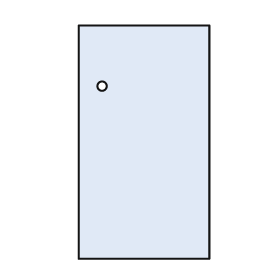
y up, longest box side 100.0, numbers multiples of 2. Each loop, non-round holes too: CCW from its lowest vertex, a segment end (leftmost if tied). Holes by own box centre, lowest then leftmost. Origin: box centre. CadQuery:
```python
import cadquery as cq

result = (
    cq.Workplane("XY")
    .moveTo(-28.0, -50.0)
    .lineTo(28.0, -50.0)
    .lineTo(28.0, 50.0)
    .lineTo(-28.0, 50.0)
    .close()
    .moveTo(-18.0, 24.0)
    .circle(2.0)
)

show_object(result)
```